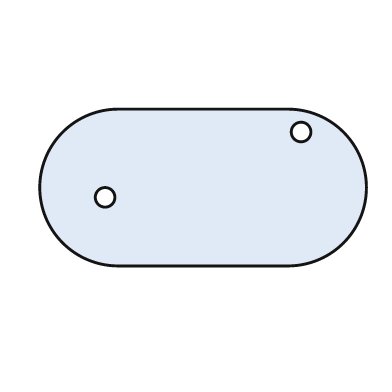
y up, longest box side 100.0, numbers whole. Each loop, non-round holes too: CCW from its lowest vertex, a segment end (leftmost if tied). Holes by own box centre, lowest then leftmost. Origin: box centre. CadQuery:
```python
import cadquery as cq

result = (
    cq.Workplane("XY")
    .moveTo(-26.0, -24.0)
    .lineTo(26.0, -24.0)
    .threePointArc((50.0, 0.0), (26.0, 24.0))
    .lineTo(-26.0, 24.0)
    .threePointArc((-50.0, 0.0), (-26.0, -24.0))
    .close()
    .moveTo(-30.0, -3.0)
    .circle(3.0)
    .moveTo(30.0, 17.0)
    .circle(3.0)
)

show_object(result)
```